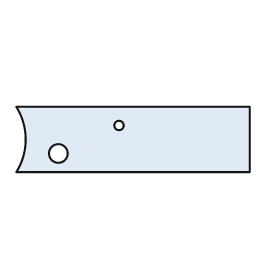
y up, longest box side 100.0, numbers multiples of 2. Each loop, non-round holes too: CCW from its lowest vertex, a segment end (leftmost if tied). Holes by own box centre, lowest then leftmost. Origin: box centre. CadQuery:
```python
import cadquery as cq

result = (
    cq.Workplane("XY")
    .moveTo(-50.0, -14.0)
    .lineTo(50.0, -14.0)
    .lineTo(50.0, 14.0)
    .lineTo(-50.0, 14.0)
    .threePointArc((-46.0, 0.0), (-50.0, -14.0))
    .close()
    .moveTo(-32.0, -6.0)
    .circle(4.0)
    .moveTo(-6.0, 6.0)
    .circle(2.0)
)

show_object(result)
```